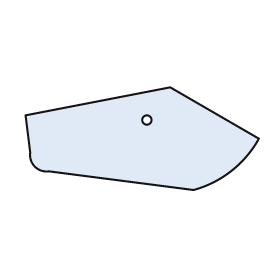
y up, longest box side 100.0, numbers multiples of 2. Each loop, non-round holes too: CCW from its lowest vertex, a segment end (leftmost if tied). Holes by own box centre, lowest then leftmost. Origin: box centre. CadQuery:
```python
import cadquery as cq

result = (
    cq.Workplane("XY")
    .moveTo(22.0, -22.0)
    .threePointArc((38.0, -14.0), (50.0, 0.0))
    .lineTo(12.0, 22.0)
    .lineTo(-50.0, 10.0)
    .lineTo(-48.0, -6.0)
    .threePointArc((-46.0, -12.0), (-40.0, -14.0))
    .close()
    .moveTo(2.0, 8.0)
    .circle(2.0)
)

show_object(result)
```